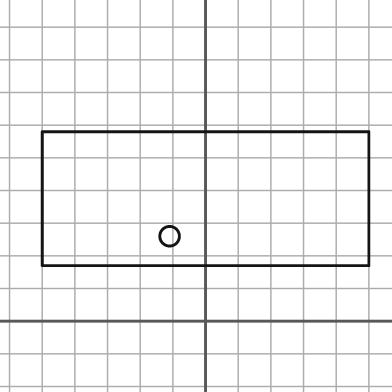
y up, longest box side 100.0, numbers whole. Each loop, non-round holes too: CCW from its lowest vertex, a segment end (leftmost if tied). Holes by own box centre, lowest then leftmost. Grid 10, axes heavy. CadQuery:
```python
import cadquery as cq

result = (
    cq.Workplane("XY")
    .moveTo(-50.0, 17.0)
    .lineTo(50.0, 17.0)
    .lineTo(50.0, 58.0)
    .lineTo(-50.0, 58.0)
    .close()
    .moveTo(-11.0, 26.0)
    .circle(3.0)
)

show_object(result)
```